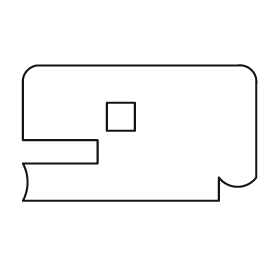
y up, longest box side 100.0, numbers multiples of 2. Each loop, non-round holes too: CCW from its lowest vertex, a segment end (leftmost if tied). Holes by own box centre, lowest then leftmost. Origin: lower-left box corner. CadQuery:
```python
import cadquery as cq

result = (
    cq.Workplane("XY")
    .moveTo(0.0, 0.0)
    .lineTo(84.0, 0.0)
    .lineTo(84.0, 10.0)
    .threePointArc((92.0, 6.0), (100.0, 10.0))
    .lineTo(100.0, 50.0)
    .threePointArc((98.0, 56.0), (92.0, 58.0))
    .lineTo(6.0, 58.0)
    .threePointArc((2.0, 56.0), (0.0, 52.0))
    .lineTo(0.0, 26.0)
    .lineTo(32.0, 26.0)
    .lineTo(32.0, 16.0)
    .lineTo(0.0, 16.0)
    .threePointArc((2.0, 8.0), (0.0, 0.0))
    .close()
    .moveTo(36.0, 30.0)
    .lineTo(48.0, 30.0)
    .lineTo(48.0, 42.0)
    .lineTo(36.0, 42.0)
    .close()
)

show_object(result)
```